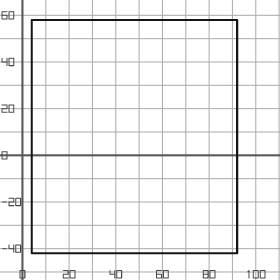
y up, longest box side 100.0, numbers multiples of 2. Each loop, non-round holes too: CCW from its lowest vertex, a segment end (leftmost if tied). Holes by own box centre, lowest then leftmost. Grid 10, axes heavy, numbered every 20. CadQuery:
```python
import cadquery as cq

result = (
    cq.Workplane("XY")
    .moveTo(4.0, -42.0)
    .lineTo(92.0, -42.0)
    .lineTo(92.0, 58.0)
    .lineTo(4.0, 58.0)
    .close()
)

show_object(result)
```